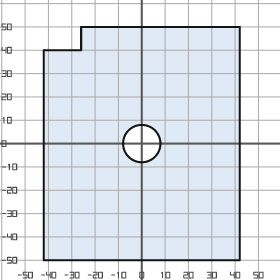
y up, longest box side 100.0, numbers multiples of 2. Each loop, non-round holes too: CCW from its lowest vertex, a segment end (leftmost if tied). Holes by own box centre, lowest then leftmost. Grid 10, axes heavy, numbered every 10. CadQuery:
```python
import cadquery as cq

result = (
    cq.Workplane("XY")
    .moveTo(-42.0, -50.0)
    .lineTo(42.0, -50.0)
    .lineTo(42.0, 50.0)
    .lineTo(-26.0, 50.0)
    .lineTo(-26.0, 40.0)
    .lineTo(-42.0, 40.0)
    .close()
    .moveTo(0.0, 0.0)
    .circle(8.0)
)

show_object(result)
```